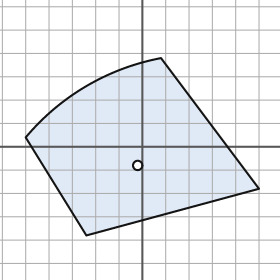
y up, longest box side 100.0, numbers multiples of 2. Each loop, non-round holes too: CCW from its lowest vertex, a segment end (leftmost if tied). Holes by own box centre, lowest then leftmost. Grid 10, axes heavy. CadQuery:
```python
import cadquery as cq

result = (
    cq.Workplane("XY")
    .moveTo(-24.0, -38.0)
    .lineTo(50.0, -18.0)
    .lineTo(8.0, 38.0)
    .threePointArc((-24.0, 26.0), (-50.0, 4.0))
    .close()
    .moveTo(-2.0, -8.0)
    .circle(2.0)
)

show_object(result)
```